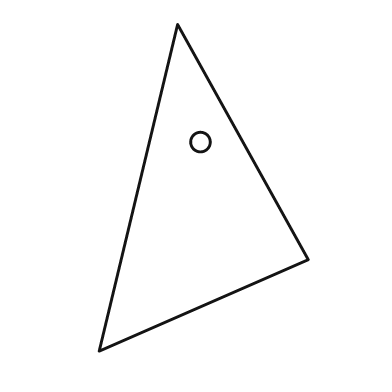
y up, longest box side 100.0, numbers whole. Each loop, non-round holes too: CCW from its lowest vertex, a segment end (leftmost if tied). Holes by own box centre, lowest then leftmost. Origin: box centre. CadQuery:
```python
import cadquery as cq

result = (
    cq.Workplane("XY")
    .moveTo(-32.0, -50.0)
    .lineTo(32.0, -22.0)
    .lineTo(-8.0, 50.0)
    .close()
    .moveTo(-1.0, 14.0)
    .circle(3.0)
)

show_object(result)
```